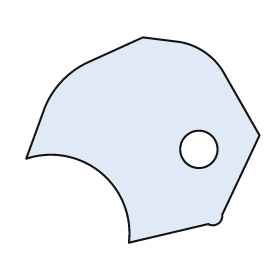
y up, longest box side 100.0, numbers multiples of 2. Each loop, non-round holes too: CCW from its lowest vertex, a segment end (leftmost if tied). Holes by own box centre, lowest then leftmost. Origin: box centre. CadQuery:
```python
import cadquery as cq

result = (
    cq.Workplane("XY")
    .moveTo(-6.0, -44.0)
    .lineTo(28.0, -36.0)
    .threePointArc((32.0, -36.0), (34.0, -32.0))
    .lineTo(50.0, 2.0)
    .lineTo(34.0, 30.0)
    .threePointArc((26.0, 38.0), (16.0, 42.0))
    .lineTo(0.0, 44.0)
    .lineTo(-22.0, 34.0)
    .threePointArc((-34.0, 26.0), (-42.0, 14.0))
    .lineTo(-50.0, -8.0)
    .threePointArc((-18.0, -14.0), (-6.0, -44.0))
    .close()
    .moveTo(24.0, -4.0)
    .circle(8.0)
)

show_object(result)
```